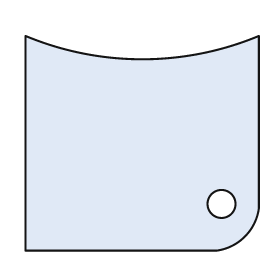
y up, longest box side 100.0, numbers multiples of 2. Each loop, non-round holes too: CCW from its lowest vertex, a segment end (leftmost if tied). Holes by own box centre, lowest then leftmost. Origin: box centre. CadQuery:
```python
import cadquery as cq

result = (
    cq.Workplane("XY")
    .moveTo(-50.0, -46.0)
    .lineTo(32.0, -46.0)
    .threePointArc((44.0, -40.0), (50.0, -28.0))
    .lineTo(50.0, 46.0)
    .threePointArc((0.0, 36.0), (-50.0, 46.0))
    .close()
    .moveTo(34.0, -26.0)
    .circle(6.0)
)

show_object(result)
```